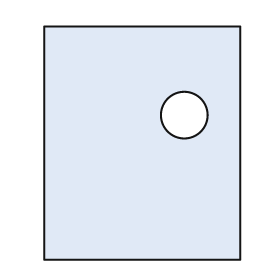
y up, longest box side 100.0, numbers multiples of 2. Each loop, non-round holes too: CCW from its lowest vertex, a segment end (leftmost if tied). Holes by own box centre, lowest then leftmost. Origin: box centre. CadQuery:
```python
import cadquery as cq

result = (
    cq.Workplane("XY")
    .moveTo(-42.0, -50.0)
    .lineTo(42.0, -50.0)
    .lineTo(42.0, 50.0)
    .lineTo(-42.0, 50.0)
    .close()
    .moveTo(18.0, 12.0)
    .circle(10.0)
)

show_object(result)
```